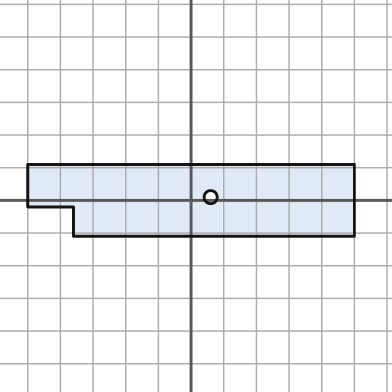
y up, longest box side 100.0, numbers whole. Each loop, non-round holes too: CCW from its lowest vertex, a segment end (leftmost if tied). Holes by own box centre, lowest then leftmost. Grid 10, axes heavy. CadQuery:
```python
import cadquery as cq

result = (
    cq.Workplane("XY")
    .moveTo(-36.0, -11.0)
    .lineTo(50.0, -11.0)
    .lineTo(50.0, 11.0)
    .lineTo(-50.0, 11.0)
    .lineTo(-50.0, -2.0)
    .lineTo(-36.0, -2.0)
    .close()
    .moveTo(6.0, 1.0)
    .circle(2.0)
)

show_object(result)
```